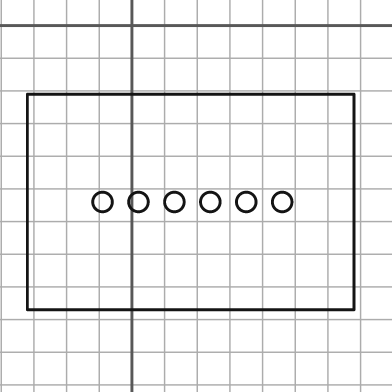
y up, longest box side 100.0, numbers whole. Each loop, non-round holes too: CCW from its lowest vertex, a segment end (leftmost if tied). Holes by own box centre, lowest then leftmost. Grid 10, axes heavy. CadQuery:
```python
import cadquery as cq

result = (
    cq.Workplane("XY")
    .moveTo(-32.0, -87.0)
    .lineTo(68.0, -87.0)
    .lineTo(68.0, -21.0)
    .lineTo(-32.0, -21.0)
    .close()
    .moveTo(-9.0, -54.0)
    .circle(3.0)
    .moveTo(2.0, -54.0)
    .circle(3.0)
    .moveTo(13.0, -54.0)
    .circle(3.0)
    .moveTo(24.0, -54.0)
    .circle(3.0)
    .moveTo(35.0, -54.0)
    .circle(3.0)
    .moveTo(46.0, -54.0)
    .circle(3.0)
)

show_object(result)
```